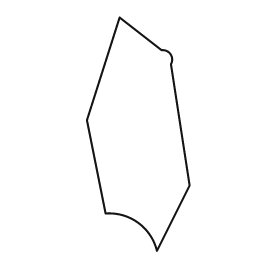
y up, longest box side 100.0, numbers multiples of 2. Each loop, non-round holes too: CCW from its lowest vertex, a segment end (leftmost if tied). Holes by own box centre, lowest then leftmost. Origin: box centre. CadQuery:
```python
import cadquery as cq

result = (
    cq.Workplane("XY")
    .moveTo(8.0, -50.0)
    .lineTo(22.0, -22.0)
    .lineTo(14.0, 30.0)
    .threePointArc((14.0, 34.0), (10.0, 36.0))
    .lineTo(-8.0, 50.0)
    .lineTo(-22.0, 6.0)
    .lineTo(-14.0, -34.0)
    .threePointArc((0.0, -38.0), (8.0, -50.0))
    .close()
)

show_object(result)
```